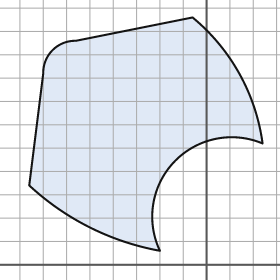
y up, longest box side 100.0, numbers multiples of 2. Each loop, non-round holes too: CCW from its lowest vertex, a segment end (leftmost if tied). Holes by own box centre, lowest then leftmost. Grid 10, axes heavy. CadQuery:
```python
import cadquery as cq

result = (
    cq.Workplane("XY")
    .moveTo(-20.0, 6.0)
    .threePointArc((-14.0, 44.0), (24.0, 52.0))
    .threePointArc((14.0, 82.0), (-6.0, 106.0))
    .lineTo(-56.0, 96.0)
    .threePointArc((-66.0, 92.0), (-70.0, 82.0))
    .lineTo(-76.0, 34.0)
    .threePointArc((-50.0, 16.0), (-20.0, 6.0))
    .close()
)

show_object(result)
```